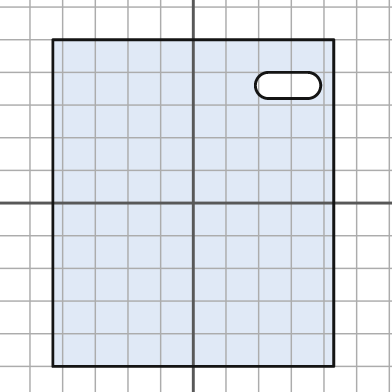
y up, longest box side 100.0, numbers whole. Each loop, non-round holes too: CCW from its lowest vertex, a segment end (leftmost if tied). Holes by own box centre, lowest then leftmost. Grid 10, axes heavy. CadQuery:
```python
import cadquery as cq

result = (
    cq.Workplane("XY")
    .moveTo(-43.0, -50.0)
    .lineTo(43.0, -50.0)
    .lineTo(43.0, 50.0)
    .lineTo(-43.0, 50.0)
    .close()
    .moveTo(23.0, 32.0)
    .lineTo(35.0, 32.0)
    .threePointArc((39.0, 36.0), (35.0, 40.0))
    .lineTo(23.0, 40.0)
    .threePointArc((19.0, 36.0), (23.0, 32.0))
    .close()
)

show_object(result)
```